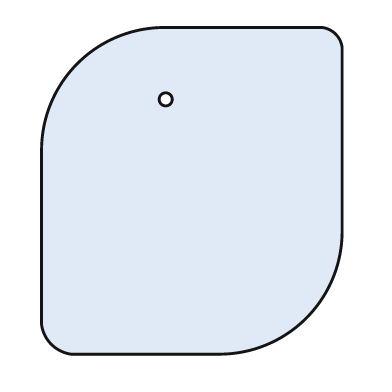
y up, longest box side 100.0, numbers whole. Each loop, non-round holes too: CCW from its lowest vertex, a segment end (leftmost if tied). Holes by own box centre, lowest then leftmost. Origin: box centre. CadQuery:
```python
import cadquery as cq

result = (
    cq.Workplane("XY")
    .moveTo(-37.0, -50.0)
    .lineTo(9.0, -50.0)
    .threePointArc((35.0, -39.0), (46.0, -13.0))
    .lineTo(46.0, 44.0)
    .threePointArc((44.0, 48.0), (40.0, 50.0))
    .lineTo(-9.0, 50.0)
    .threePointArc((-35.0, 39.0), (-46.0, 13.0))
    .lineTo(-46.0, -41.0)
    .threePointArc((-43.0, -47.0), (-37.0, -50.0))
    .close()
    .moveTo(-8.0, 28.0)
    .circle(2.0)
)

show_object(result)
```